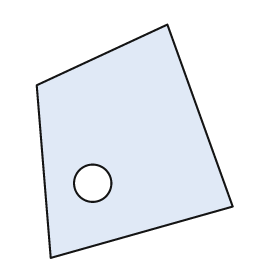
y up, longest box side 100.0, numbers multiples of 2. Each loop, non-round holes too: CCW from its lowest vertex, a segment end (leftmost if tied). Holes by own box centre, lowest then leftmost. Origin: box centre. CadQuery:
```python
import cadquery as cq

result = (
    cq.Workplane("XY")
    .moveTo(-36.0, -50.0)
    .lineTo(42.0, -28.0)
    .lineTo(14.0, 50.0)
    .lineTo(-42.0, 24.0)
    .close()
    .moveTo(-18.0, -18.0)
    .circle(8.0)
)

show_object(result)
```